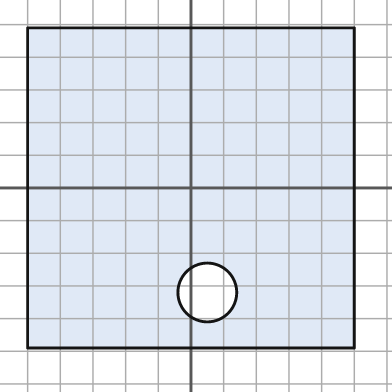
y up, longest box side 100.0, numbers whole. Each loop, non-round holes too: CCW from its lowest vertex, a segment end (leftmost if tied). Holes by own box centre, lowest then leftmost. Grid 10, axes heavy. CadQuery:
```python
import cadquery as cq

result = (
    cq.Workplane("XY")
    .moveTo(-50.0, -49.0)
    .lineTo(50.0, -49.0)
    .lineTo(50.0, 49.0)
    .lineTo(-50.0, 49.0)
    .close()
    .moveTo(5.0, -32.0)
    .circle(9.0)
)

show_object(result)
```